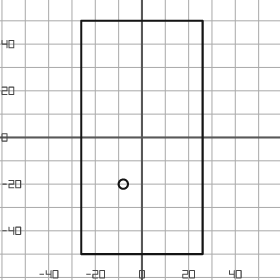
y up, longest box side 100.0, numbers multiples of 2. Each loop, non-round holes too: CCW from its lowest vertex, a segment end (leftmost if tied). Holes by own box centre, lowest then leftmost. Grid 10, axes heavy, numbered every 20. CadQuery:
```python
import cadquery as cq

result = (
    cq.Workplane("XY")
    .moveTo(-26.0, -50.0)
    .lineTo(26.0, -50.0)
    .lineTo(26.0, 50.0)
    .lineTo(-26.0, 50.0)
    .close()
    .moveTo(-8.0, -20.0)
    .circle(2.0)
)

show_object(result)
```